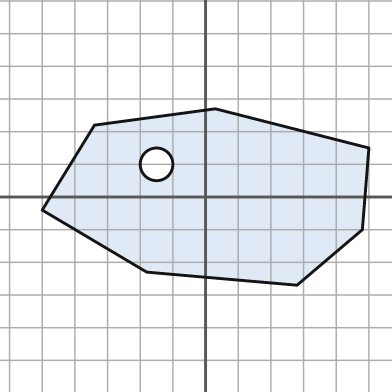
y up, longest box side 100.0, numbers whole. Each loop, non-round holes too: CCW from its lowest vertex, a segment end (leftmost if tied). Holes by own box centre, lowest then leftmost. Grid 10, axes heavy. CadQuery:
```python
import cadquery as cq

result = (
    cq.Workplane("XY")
    .moveTo(28.0, -27.0)
    .lineTo(48.0, -10.0)
    .lineTo(50.0, 15.0)
    .lineTo(3.0, 27.0)
    .lineTo(-34.0, 22.0)
    .lineTo(-50.0, -4.0)
    .lineTo(-18.0, -23.0)
    .close()
    .moveTo(-15.0, 10.0)
    .circle(5.0)
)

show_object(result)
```